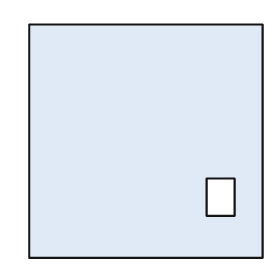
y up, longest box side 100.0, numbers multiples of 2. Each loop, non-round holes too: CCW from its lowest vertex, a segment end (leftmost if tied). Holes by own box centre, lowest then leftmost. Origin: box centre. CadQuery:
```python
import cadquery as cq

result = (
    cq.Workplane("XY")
    .moveTo(-50.0, -50.0)
    .lineTo(50.0, -50.0)
    .lineTo(50.0, 50.0)
    .lineTo(-50.0, 50.0)
    .close()
    .moveTo(26.0, -32.0)
    .lineTo(38.0, -32.0)
    .lineTo(38.0, -16.0)
    .lineTo(26.0, -16.0)
    .close()
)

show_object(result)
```